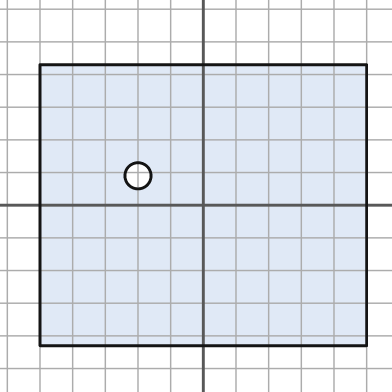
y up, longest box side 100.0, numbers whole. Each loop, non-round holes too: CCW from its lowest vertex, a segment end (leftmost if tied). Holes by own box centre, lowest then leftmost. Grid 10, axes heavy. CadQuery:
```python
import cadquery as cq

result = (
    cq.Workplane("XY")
    .moveTo(-50.0, -43.0)
    .lineTo(50.0, -43.0)
    .lineTo(50.0, 43.0)
    .lineTo(-50.0, 43.0)
    .close()
    .moveTo(-20.0, 9.0)
    .circle(4.0)
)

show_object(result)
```